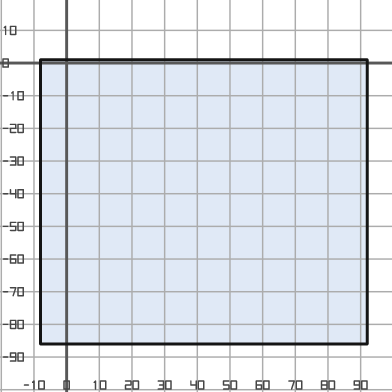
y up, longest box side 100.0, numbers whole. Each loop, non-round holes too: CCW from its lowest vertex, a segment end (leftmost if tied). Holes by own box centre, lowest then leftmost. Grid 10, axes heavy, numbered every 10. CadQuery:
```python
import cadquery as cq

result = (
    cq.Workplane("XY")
    .moveTo(-8.0, -86.0)
    .lineTo(92.0, -86.0)
    .lineTo(92.0, 1.0)
    .lineTo(-8.0, 1.0)
    .close()
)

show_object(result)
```